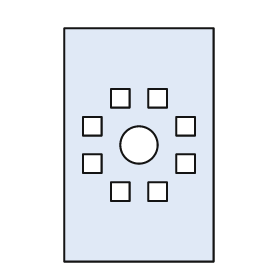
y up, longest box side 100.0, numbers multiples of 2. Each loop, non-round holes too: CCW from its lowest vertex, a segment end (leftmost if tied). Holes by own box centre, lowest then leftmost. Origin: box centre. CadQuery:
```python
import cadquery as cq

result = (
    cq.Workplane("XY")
    .moveTo(-32.0, -50.0)
    .lineTo(32.0, -50.0)
    .lineTo(32.0, 50.0)
    .lineTo(-32.0, 50.0)
    .close()
    .moveTo(-12.0, -24.0)
    .lineTo(-4.0, -24.0)
    .lineTo(-4.0, -16.0)
    .lineTo(-12.0, -16.0)
    .close()
    .moveTo(4.0, -24.0)
    .lineTo(12.0, -24.0)
    .lineTo(12.0, -16.0)
    .lineTo(4.0, -16.0)
    .close()
    .moveTo(-24.0, -12.0)
    .lineTo(-16.0, -12.0)
    .lineTo(-16.0, -4.0)
    .lineTo(-24.0, -4.0)
    .close()
    .moveTo(16.0, -12.0)
    .lineTo(24.0, -12.0)
    .lineTo(24.0, -4.0)
    .lineTo(16.0, -4.0)
    .close()
    .moveTo(0.0, 0.0)
    .circle(8.0)
    .moveTo(-24.0, 4.0)
    .lineTo(-16.0, 4.0)
    .lineTo(-16.0, 12.0)
    .lineTo(-24.0, 12.0)
    .close()
    .moveTo(16.0, 4.0)
    .lineTo(24.0, 4.0)
    .lineTo(24.0, 12.0)
    .lineTo(16.0, 12.0)
    .close()
    .moveTo(-12.0, 16.0)
    .lineTo(-4.0, 16.0)
    .lineTo(-4.0, 24.0)
    .lineTo(-12.0, 24.0)
    .close()
    .moveTo(4.0, 16.0)
    .lineTo(12.0, 16.0)
    .lineTo(12.0, 24.0)
    .lineTo(4.0, 24.0)
    .close()
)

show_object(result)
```